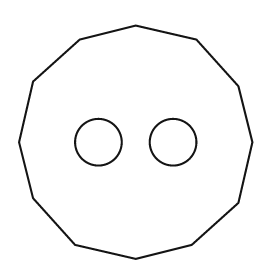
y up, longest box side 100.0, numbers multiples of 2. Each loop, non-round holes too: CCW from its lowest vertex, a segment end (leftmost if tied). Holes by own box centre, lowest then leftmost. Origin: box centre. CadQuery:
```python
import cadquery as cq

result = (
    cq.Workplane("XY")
    .moveTo(0.0, -50.0)
    .lineTo(24.0, -44.0)
    .lineTo(44.0, -26.0)
    .lineTo(50.0, 0.0)
    .lineTo(44.0, 24.0)
    .lineTo(26.0, 44.0)
    .lineTo(0.0, 50.0)
    .lineTo(-24.0, 44.0)
    .lineTo(-44.0, 26.0)
    .lineTo(-50.0, 0.0)
    .lineTo(-44.0, -24.0)
    .lineTo(-26.0, -44.0)
    .close()
    .moveTo(-16.0, 0.0)
    .circle(10.0)
    .moveTo(16.0, 0.0)
    .circle(10.0)
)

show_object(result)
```